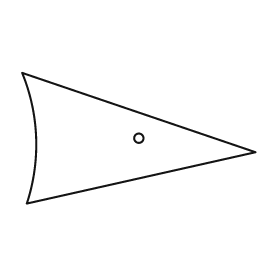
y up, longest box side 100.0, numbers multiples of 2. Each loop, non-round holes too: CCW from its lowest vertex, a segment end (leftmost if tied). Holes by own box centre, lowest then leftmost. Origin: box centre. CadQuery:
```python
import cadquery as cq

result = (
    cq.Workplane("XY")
    .moveTo(-48.0, -28.0)
    .lineTo(50.0, -6.0)
    .lineTo(-50.0, 28.0)
    .threePointArc((-44.0, 0.0), (-48.0, -28.0))
    .close()
    .moveTo(0.0, 0.0)
    .circle(2.0)
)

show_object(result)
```